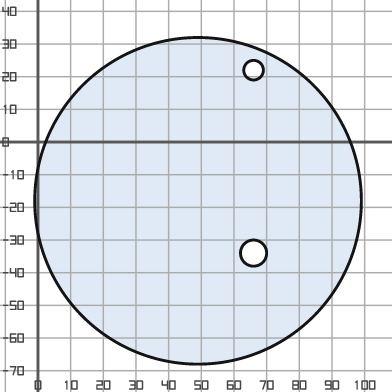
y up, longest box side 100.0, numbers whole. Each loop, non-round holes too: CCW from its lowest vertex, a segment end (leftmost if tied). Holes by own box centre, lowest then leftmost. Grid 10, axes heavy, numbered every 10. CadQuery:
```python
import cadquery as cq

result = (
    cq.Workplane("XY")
    .moveTo(49.0, -18.0)
    .circle(50.0)
    .moveTo(66.0, -34.0)
    .circle(4.0)
    .moveTo(66.0, 22.0)
    .circle(3.0)
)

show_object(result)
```